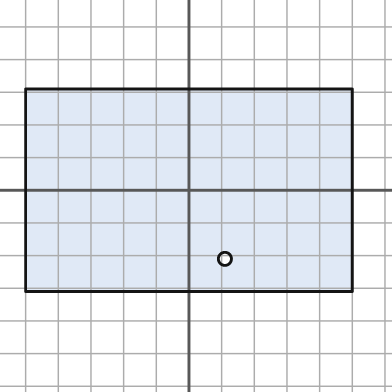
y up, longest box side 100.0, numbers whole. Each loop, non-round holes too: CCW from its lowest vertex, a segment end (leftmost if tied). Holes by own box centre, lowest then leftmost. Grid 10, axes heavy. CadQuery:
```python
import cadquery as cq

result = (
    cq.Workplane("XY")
    .moveTo(-50.0, -31.0)
    .lineTo(50.0, -31.0)
    .lineTo(50.0, 31.0)
    .lineTo(-50.0, 31.0)
    .close()
    .moveTo(11.0, -21.0)
    .circle(2.0)
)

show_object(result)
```